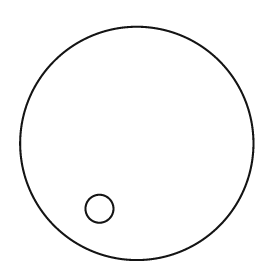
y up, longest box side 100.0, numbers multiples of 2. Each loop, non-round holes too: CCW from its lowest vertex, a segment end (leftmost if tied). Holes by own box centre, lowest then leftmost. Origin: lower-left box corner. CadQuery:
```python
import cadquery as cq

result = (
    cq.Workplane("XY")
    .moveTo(50.0, 50.0)
    .circle(50.0)
    .moveTo(34.0, 22.0)
    .circle(6.0)
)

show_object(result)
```